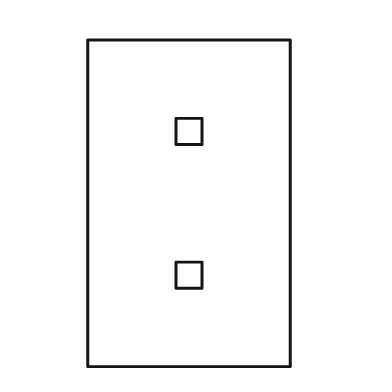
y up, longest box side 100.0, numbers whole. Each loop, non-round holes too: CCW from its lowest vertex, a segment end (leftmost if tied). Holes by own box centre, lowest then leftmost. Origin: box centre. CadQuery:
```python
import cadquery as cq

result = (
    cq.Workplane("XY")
    .moveTo(-31.0, -50.0)
    .lineTo(31.0, -50.0)
    .lineTo(31.0, 50.0)
    .lineTo(-31.0, 50.0)
    .close()
    .moveTo(-4.0, -26.0)
    .lineTo(4.0, -26.0)
    .lineTo(4.0, -18.0)
    .lineTo(-4.0, -18.0)
    .close()
    .moveTo(-4.0, 18.0)
    .lineTo(4.0, 18.0)
    .lineTo(4.0, 26.0)
    .lineTo(-4.0, 26.0)
    .close()
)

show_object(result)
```